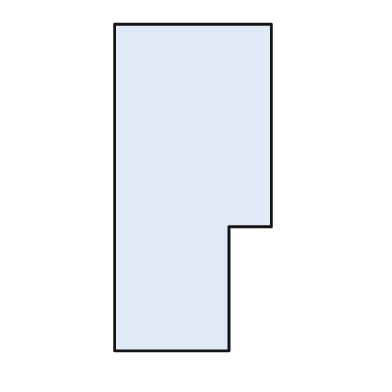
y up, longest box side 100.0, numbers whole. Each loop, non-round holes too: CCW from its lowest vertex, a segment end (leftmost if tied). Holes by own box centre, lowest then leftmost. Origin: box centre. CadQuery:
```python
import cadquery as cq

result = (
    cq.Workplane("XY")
    .moveTo(-24.0, -50.0)
    .lineTo(11.0, -50.0)
    .lineTo(11.0, -12.0)
    .lineTo(24.0, -12.0)
    .lineTo(24.0, 50.0)
    .lineTo(-24.0, 50.0)
    .close()
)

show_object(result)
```